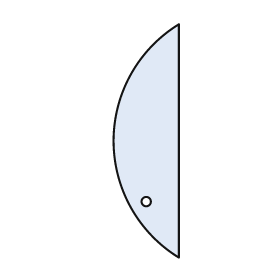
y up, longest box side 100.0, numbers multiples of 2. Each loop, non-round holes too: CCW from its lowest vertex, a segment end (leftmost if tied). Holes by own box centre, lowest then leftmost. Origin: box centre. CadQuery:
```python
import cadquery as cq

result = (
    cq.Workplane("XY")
    .moveTo(14.0, -50.0)
    .lineTo(14.0, 50.0)
    .threePointArc((-14.0, 0.0), (14.0, -50.0))
    .close()
    .moveTo(0.0, -26.0)
    .circle(2.0)
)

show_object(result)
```